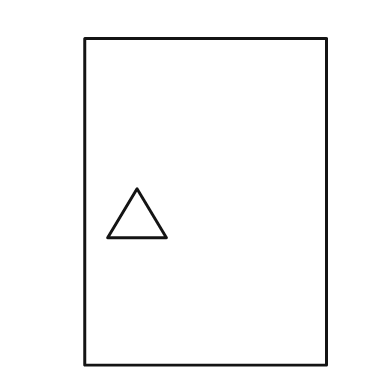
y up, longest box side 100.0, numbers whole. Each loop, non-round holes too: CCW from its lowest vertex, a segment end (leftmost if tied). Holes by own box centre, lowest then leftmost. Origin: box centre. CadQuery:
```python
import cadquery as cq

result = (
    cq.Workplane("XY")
    .moveTo(-37.0, -50.0)
    .lineTo(37.0, -50.0)
    .lineTo(37.0, 50.0)
    .lineTo(-37.0, 50.0)
    .close()
    .moveTo(-30.0, -11.0)
    .lineTo(-12.0, -11.0)
    .lineTo(-21.0, 4.0)
    .close()
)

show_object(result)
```